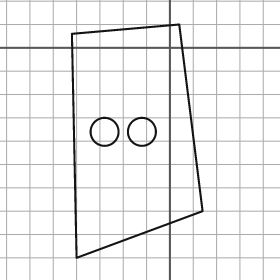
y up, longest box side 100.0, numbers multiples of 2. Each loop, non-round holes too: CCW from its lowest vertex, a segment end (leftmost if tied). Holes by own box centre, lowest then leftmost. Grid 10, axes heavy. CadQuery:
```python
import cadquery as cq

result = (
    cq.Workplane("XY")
    .moveTo(-40.0, -90.0)
    .lineTo(14.0, -70.0)
    .lineTo(4.0, 10.0)
    .lineTo(-42.0, 6.0)
    .close()
    .moveTo(-28.0, -36.0)
    .circle(6.0)
    .moveTo(-12.0, -36.0)
    .circle(6.0)
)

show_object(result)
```